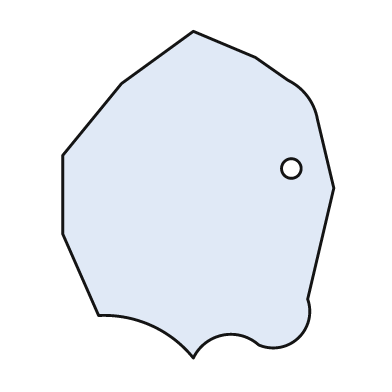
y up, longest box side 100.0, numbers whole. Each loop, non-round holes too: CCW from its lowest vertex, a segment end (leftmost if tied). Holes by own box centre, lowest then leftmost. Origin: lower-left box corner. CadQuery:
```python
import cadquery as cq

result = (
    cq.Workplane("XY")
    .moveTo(40.0, 0.0)
    .threePointArc((49.0, 7.0), (60.0, 4.0))
    .threePointArc((72.0, 6.0), (75.0, 18.0))
    .lineTo(83.0, 52.0)
    .lineTo(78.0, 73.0)
    .threePointArc((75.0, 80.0), (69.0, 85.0))
    .lineTo(59.0, 92.0)
    .lineTo(40.0, 100.0)
    .lineTo(18.0, 84.0)
    .lineTo(0.0, 62.0)
    .lineTo(0.0, 38.0)
    .lineTo(11.0, 13.0)
    .threePointArc((27.0, 10.0), (40.0, 0.0))
    .close()
    .moveTo(70.0, 58.0)
    .circle(3.0)
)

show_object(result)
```